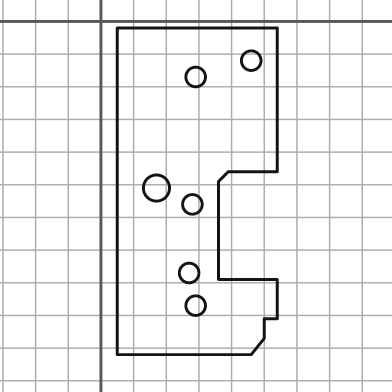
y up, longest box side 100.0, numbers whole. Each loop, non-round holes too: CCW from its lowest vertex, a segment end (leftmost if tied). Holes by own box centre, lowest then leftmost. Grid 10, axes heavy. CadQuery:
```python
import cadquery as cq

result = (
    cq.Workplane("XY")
    .moveTo(5.0, -102.0)
    .lineTo(46.0, -102.0)
    .lineTo(50.0, -97.0)
    .lineTo(50.0, -91.0)
    .lineTo(54.0, -91.0)
    .lineTo(54.0, -79.0)
    .lineTo(36.0, -79.0)
    .lineTo(36.0, -49.0)
    .lineTo(39.0, -46.0)
    .lineTo(54.0, -46.0)
    .lineTo(54.0, -2.0)
    .lineTo(5.0, -2.0)
    .close()
    .moveTo(29.0, -87.0)
    .circle(3.0)
    .moveTo(27.0, -77.0)
    .circle(3.0)
    .moveTo(28.0, -56.0)
    .circle(3.0)
    .moveTo(17.0, -51.0)
    .circle(4.0)
    .moveTo(29.0, -17.0)
    .circle(3.0)
    .moveTo(46.0, -12.0)
    .circle(3.0)
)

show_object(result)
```